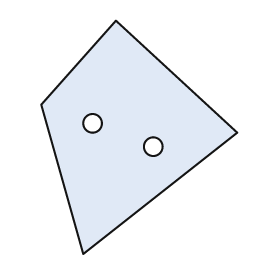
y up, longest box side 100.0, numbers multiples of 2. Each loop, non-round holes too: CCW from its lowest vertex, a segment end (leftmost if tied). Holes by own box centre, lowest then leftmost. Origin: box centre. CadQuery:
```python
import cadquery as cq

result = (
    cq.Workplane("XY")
    .moveTo(-24.0, -50.0)
    .lineTo(42.0, 2.0)
    .lineTo(-10.0, 50.0)
    .lineTo(-42.0, 14.0)
    .close()
    .moveTo(6.0, -4.0)
    .circle(4.0)
    .moveTo(-20.0, 6.0)
    .circle(4.0)
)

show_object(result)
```